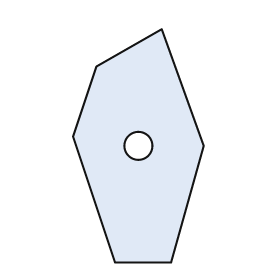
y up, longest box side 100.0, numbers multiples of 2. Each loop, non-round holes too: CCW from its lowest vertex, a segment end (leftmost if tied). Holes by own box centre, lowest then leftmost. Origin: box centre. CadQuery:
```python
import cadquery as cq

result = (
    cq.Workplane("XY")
    .moveTo(-10.0, -50.0)
    .lineTo(14.0, -50.0)
    .lineTo(28.0, 0.0)
    .lineTo(10.0, 50.0)
    .lineTo(-18.0, 34.0)
    .lineTo(-28.0, 4.0)
    .close()
    .moveTo(0.0, 0.0)
    .circle(6.0)
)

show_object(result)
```